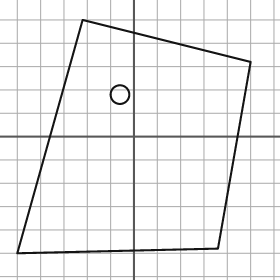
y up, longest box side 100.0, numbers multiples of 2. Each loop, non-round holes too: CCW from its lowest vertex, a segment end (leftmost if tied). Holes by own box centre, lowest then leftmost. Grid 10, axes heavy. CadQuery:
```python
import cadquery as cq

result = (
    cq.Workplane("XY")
    .moveTo(-50.0, -50.0)
    .lineTo(36.0, -48.0)
    .lineTo(50.0, 32.0)
    .lineTo(-22.0, 50.0)
    .close()
    .moveTo(-6.0, 18.0)
    .circle(4.0)
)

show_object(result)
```